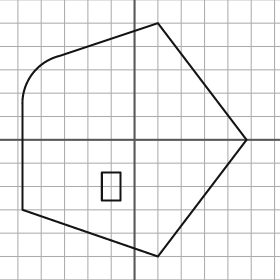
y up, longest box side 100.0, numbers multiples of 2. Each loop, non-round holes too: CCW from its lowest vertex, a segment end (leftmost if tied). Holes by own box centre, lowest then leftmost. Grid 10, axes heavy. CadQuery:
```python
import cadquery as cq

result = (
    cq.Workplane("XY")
    .moveTo(10.0, -50.0)
    .lineTo(48.0, 0.0)
    .lineTo(10.0, 50.0)
    .lineTo(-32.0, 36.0)
    .threePointArc((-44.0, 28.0), (-48.0, 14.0))
    .lineTo(-48.0, -30.0)
    .close()
    .moveTo(-14.0, -26.0)
    .lineTo(-6.0, -26.0)
    .lineTo(-6.0, -14.0)
    .lineTo(-14.0, -14.0)
    .close()
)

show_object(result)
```